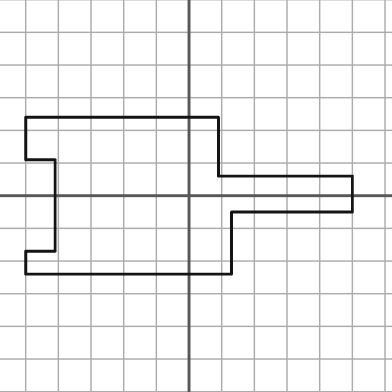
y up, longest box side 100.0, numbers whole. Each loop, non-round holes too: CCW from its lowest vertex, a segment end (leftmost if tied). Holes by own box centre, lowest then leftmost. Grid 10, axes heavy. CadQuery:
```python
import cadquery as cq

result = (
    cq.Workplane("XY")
    .moveTo(-50.0, -24.0)
    .lineTo(13.0, -24.0)
    .lineTo(13.0, -5.0)
    .lineTo(50.0, -5.0)
    .lineTo(50.0, 6.0)
    .lineTo(9.0, 6.0)
    .lineTo(9.0, 24.0)
    .lineTo(-50.0, 24.0)
    .lineTo(-50.0, 11.0)
    .lineTo(-41.0, 11.0)
    .lineTo(-41.0, -17.0)
    .lineTo(-50.0, -17.0)
    .close()
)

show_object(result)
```